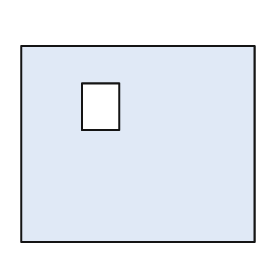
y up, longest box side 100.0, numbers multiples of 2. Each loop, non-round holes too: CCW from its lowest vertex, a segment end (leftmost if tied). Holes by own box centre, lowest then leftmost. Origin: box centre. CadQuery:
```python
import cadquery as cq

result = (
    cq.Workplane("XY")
    .moveTo(-50.0, -42.0)
    .lineTo(50.0, -42.0)
    .lineTo(50.0, 42.0)
    .lineTo(-50.0, 42.0)
    .close()
    .moveTo(-24.0, 6.0)
    .lineTo(-8.0, 6.0)
    .lineTo(-8.0, 26.0)
    .lineTo(-24.0, 26.0)
    .close()
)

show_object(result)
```